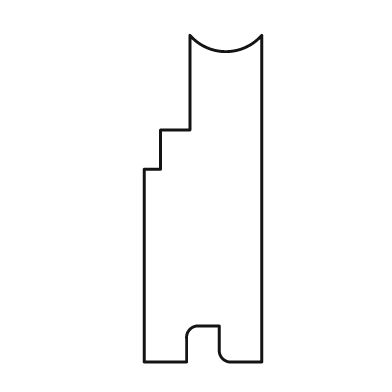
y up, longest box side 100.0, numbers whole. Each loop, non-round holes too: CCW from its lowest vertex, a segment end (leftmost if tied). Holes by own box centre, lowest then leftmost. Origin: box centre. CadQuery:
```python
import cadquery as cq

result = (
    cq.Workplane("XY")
    .moveTo(-18.0, -50.0)
    .lineTo(-5.0, -50.0)
    .lineTo(-5.0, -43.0)
    .threePointArc((-4.0, -40.0), (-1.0, -39.0))
    .lineTo(5.0, -39.0)
    .lineTo(5.0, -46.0)
    .threePointArc((6.0, -49.0), (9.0, -50.0))
    .lineTo(18.0, -50.0)
    .lineTo(18.0, 50.0)
    .threePointArc((7.0, 45.0), (-4.0, 50.0))
    .lineTo(-4.0, 21.0)
    .lineTo(-13.0, 21.0)
    .lineTo(-13.0, 9.0)
    .lineTo(-18.0, 9.0)
    .close()
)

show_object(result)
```